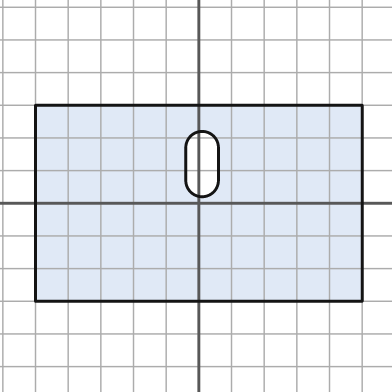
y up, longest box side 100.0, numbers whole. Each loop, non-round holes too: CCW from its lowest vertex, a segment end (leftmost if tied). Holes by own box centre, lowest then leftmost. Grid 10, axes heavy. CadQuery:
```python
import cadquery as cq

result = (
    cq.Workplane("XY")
    .moveTo(-50.0, -30.0)
    .lineTo(50.0, -30.0)
    .lineTo(50.0, 30.0)
    .lineTo(-50.0, 30.0)
    .close()
    .moveTo(-4.0, 7.0)
    .threePointArc((1.0, 2.0), (6.0, 7.0))
    .lineTo(6.0, 17.0)
    .threePointArc((1.0, 22.0), (-4.0, 17.0))
    .close()
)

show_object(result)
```